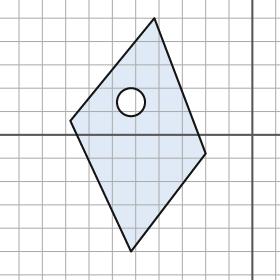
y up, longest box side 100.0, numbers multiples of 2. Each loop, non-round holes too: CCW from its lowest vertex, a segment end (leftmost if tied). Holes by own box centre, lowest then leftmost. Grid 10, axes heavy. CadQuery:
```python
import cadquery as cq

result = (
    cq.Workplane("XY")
    .moveTo(-52.0, -50.0)
    .lineTo(-20.0, -8.0)
    .lineTo(-42.0, 50.0)
    .lineTo(-78.0, 6.0)
    .close()
    .moveTo(-52.0, 14.0)
    .circle(6.0)
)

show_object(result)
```